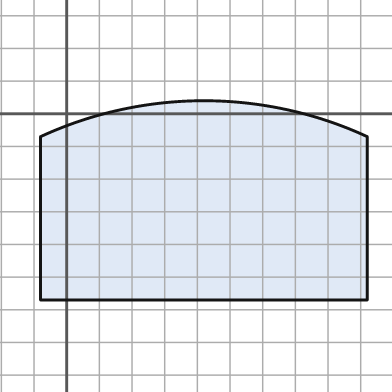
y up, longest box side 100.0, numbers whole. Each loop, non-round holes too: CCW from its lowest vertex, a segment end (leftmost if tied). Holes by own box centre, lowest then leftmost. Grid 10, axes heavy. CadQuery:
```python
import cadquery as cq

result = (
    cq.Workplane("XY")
    .moveTo(-8.0, -57.0)
    .lineTo(92.0, -57.0)
    .lineTo(92.0, -7.0)
    .threePointArc((42.0, 4.0), (-8.0, -7.0))
    .close()
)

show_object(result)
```